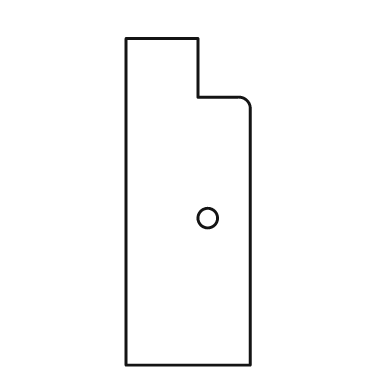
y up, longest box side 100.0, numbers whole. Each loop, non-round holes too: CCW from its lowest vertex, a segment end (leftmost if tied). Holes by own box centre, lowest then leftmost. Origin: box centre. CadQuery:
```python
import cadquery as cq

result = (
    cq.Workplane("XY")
    .moveTo(-19.0, -50.0)
    .lineTo(19.0, -50.0)
    .lineTo(19.0, 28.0)
    .threePointArc((18.0, 31.0), (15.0, 32.0))
    .lineTo(3.0, 32.0)
    .lineTo(3.0, 50.0)
    .lineTo(-19.0, 50.0)
    .close()
    .moveTo(6.0, -5.0)
    .circle(3.0)
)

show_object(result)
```